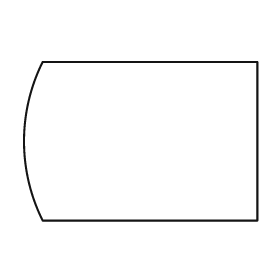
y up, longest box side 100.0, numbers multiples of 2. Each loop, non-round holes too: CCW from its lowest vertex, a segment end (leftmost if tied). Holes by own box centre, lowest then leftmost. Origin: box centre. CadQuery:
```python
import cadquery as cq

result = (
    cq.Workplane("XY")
    .moveTo(-42.0, -34.0)
    .lineTo(50.0, -34.0)
    .lineTo(50.0, 34.0)
    .lineTo(-42.0, 34.0)
    .threePointArc((-50.0, 0.0), (-42.0, -34.0))
    .close()
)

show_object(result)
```